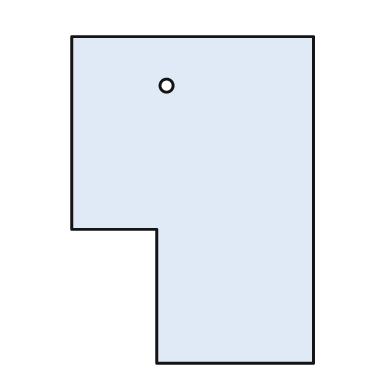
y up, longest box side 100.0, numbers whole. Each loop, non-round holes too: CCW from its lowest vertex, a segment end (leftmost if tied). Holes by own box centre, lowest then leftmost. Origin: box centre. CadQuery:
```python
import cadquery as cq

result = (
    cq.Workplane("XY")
    .moveTo(-11.0, -50.0)
    .lineTo(37.0, -50.0)
    .lineTo(37.0, 50.0)
    .lineTo(-37.0, 50.0)
    .lineTo(-37.0, -9.0)
    .lineTo(-11.0, -9.0)
    .close()
    .moveTo(-8.0, 35.0)
    .circle(2.0)
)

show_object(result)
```